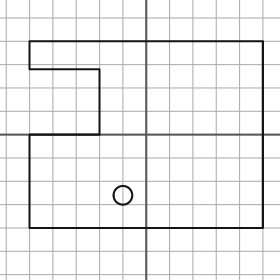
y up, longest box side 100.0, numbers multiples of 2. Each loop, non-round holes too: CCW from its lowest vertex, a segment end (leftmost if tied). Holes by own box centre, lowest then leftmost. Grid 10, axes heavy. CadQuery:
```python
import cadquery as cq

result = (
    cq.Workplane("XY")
    .moveTo(-50.0, -40.0)
    .lineTo(50.0, -40.0)
    .lineTo(50.0, 40.0)
    .lineTo(-50.0, 40.0)
    .lineTo(-50.0, 28.0)
    .lineTo(-20.0, 28.0)
    .lineTo(-20.0, 0.0)
    .lineTo(-50.0, 0.0)
    .close()
    .moveTo(-10.0, -26.0)
    .circle(4.0)
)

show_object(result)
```